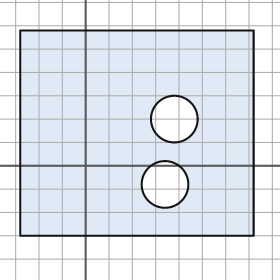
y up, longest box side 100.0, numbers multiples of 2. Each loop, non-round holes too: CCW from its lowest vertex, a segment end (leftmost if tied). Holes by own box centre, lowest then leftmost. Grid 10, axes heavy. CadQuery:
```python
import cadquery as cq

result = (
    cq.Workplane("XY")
    .moveTo(-28.0, -30.0)
    .lineTo(72.0, -30.0)
    .lineTo(72.0, 58.0)
    .lineTo(-28.0, 58.0)
    .close()
    .moveTo(34.0, -8.0)
    .circle(10.0)
    .moveTo(38.0, 20.0)
    .circle(10.0)
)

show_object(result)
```